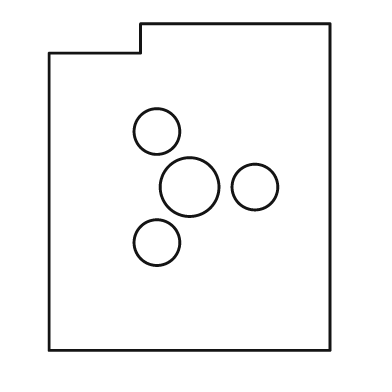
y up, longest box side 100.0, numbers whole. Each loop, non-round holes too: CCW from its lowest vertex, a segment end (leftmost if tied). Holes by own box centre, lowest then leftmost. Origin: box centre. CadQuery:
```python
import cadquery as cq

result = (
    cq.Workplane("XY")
    .moveTo(-43.0, -50.0)
    .lineTo(43.0, -50.0)
    .lineTo(43.0, 50.0)
    .lineTo(-15.0, 50.0)
    .lineTo(-15.0, 41.0)
    .lineTo(-43.0, 41.0)
    .close()
    .moveTo(-10.0, -17.0)
    .circle(7.0)
    .moveTo(0.0, 0.0)
    .circle(9.0)
    .moveTo(20.0, 0.0)
    .circle(7.0)
    .moveTo(-10.0, 17.0)
    .circle(7.0)
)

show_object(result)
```